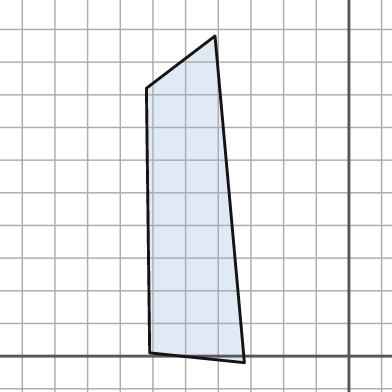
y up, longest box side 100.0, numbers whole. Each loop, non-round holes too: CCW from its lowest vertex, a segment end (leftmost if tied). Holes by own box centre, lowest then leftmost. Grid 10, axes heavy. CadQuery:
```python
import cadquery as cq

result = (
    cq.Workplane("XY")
    .moveTo(-32.0, -2.0)
    .lineTo(-41.0, 98.0)
    .lineTo(-62.0, 82.0)
    .lineTo(-61.0, 1.0)
    .close()
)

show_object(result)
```